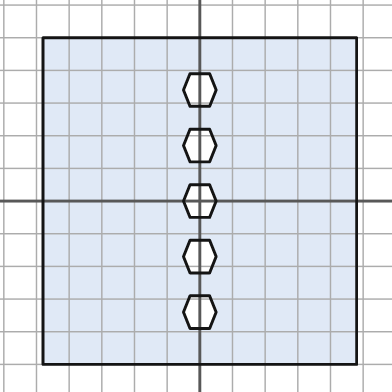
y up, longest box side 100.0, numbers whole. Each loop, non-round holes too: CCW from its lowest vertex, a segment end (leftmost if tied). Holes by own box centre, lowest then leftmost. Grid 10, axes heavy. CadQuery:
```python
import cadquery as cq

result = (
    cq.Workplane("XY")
    .moveTo(-48.0, -50.0)
    .lineTo(48.0, -50.0)
    .lineTo(48.0, 50.0)
    .lineTo(-48.0, 50.0)
    .close()
    .moveTo(-3.0, -39.0)
    .lineTo(3.0, -39.0)
    .lineTo(5.0, -34.0)
    .lineTo(3.0, -29.0)
    .lineTo(-3.0, -29.0)
    .lineTo(-5.0, -34.0)
    .close()
    .moveTo(-3.0, -22.0)
    .lineTo(3.0, -22.0)
    .lineTo(5.0, -17.0)
    .lineTo(3.0, -12.0)
    .lineTo(-3.0, -12.0)
    .lineTo(-5.0, -17.0)
    .close()
    .moveTo(-3.0, -5.0)
    .lineTo(3.0, -5.0)
    .lineTo(5.0, 0.0)
    .lineTo(3.0, 5.0)
    .lineTo(-3.0, 5.0)
    .lineTo(-5.0, 0.0)
    .close()
    .moveTo(-3.0, 12.0)
    .lineTo(3.0, 12.0)
    .lineTo(5.0, 17.0)
    .lineTo(3.0, 22.0)
    .lineTo(-3.0, 22.0)
    .lineTo(-5.0, 17.0)
    .close()
    .moveTo(-3.0, 29.0)
    .lineTo(3.0, 29.0)
    .lineTo(5.0, 34.0)
    .lineTo(3.0, 39.0)
    .lineTo(-3.0, 39.0)
    .lineTo(-5.0, 34.0)
    .close()
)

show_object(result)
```